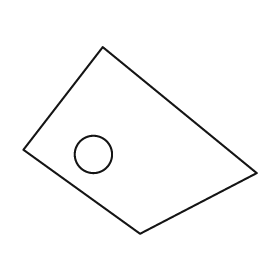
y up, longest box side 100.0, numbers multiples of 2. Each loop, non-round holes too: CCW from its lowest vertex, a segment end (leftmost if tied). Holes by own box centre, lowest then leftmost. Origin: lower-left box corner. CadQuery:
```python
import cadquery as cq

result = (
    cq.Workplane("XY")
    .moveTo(50.0, 0.0)
    .lineTo(100.0, 26.0)
    .lineTo(34.0, 80.0)
    .lineTo(0.0, 36.0)
    .close()
    .moveTo(30.0, 34.0)
    .circle(8.0)
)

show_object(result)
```